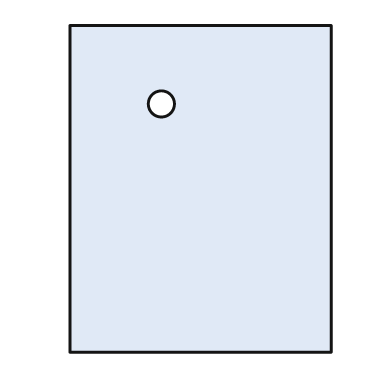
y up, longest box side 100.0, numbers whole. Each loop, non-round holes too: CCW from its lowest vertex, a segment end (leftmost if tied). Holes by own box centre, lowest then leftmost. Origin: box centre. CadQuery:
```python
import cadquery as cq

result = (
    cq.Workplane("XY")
    .moveTo(-40.0, -50.0)
    .lineTo(40.0, -50.0)
    .lineTo(40.0, 50.0)
    .lineTo(-40.0, 50.0)
    .close()
    .moveTo(-12.0, 26.0)
    .circle(4.0)
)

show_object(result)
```